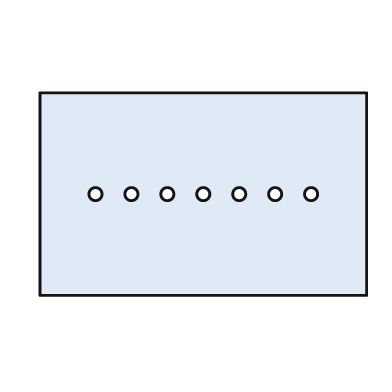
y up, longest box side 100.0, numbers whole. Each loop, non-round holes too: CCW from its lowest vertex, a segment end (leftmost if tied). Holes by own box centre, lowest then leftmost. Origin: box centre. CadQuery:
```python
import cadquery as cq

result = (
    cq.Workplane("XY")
    .moveTo(-50.0, -31.0)
    .lineTo(50.0, -31.0)
    .lineTo(50.0, 31.0)
    .lineTo(-50.0, 31.0)
    .close()
    .moveTo(-33.0, 0.0)
    .circle(2.0)
    .moveTo(-22.0, 0.0)
    .circle(2.0)
    .moveTo(-11.0, 0.0)
    .circle(2.0)
    .moveTo(0.0, 0.0)
    .circle(2.0)
    .moveTo(11.0, 0.0)
    .circle(2.0)
    .moveTo(22.0, 0.0)
    .circle(2.0)
    .moveTo(33.0, 0.0)
    .circle(2.0)
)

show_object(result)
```